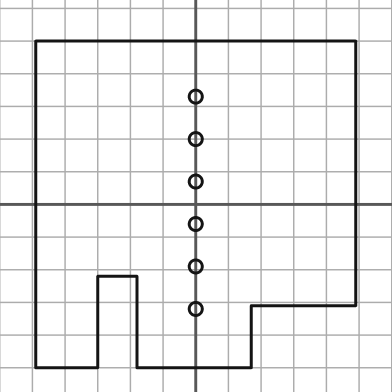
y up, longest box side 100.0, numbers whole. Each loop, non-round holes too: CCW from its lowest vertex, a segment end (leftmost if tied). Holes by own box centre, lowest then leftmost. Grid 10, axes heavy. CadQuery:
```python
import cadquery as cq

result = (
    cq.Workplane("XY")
    .moveTo(-49.0, -50.0)
    .lineTo(-30.0, -50.0)
    .lineTo(-30.0, -22.0)
    .lineTo(-18.0, -22.0)
    .lineTo(-18.0, -50.0)
    .lineTo(17.0, -50.0)
    .lineTo(17.0, -31.0)
    .lineTo(49.0, -31.0)
    .lineTo(49.0, 50.0)
    .lineTo(-49.0, 50.0)
    .close()
    .moveTo(0.0, -32.0)
    .circle(2.0)
    .moveTo(0.0, -19.0)
    .circle(2.0)
    .moveTo(0.0, -6.0)
    .circle(2.0)
    .moveTo(0.0, 7.0)
    .circle(2.0)
    .moveTo(0.0, 20.0)
    .circle(2.0)
    .moveTo(0.0, 33.0)
    .circle(2.0)
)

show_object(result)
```